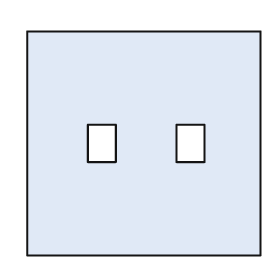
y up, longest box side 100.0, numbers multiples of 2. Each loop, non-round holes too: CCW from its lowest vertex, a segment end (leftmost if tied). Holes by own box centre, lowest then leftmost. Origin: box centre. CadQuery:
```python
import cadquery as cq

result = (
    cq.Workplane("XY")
    .moveTo(-50.0, -48.0)
    .lineTo(50.0, -48.0)
    .lineTo(50.0, 48.0)
    .lineTo(-50.0, 48.0)
    .close()
    .moveTo(-24.0, -8.0)
    .lineTo(-12.0, -8.0)
    .lineTo(-12.0, 8.0)
    .lineTo(-24.0, 8.0)
    .close()
    .moveTo(14.0, -8.0)
    .lineTo(26.0, -8.0)
    .lineTo(26.0, 8.0)
    .lineTo(14.0, 8.0)
    .close()
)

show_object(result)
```